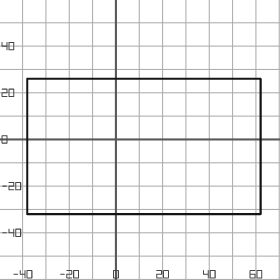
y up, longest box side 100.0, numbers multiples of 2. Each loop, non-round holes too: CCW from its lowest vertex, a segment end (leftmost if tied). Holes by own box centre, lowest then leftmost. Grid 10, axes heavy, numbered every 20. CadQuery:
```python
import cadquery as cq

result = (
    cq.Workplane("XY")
    .moveTo(-38.0, -32.0)
    .lineTo(62.0, -32.0)
    .lineTo(62.0, 26.0)
    .lineTo(-38.0, 26.0)
    .close()
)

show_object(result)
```